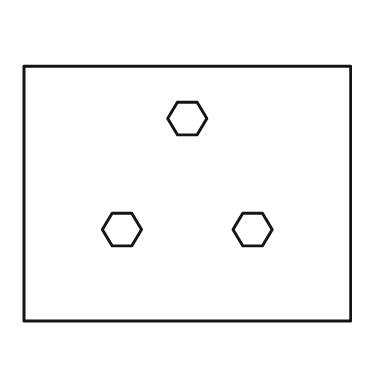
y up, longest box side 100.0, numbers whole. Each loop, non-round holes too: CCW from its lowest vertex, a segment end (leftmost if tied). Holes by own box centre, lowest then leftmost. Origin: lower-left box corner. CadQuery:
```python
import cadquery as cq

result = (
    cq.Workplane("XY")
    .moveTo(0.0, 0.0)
    .lineTo(100.0, 0.0)
    .lineTo(100.0, 78.0)
    .lineTo(0.0, 78.0)
    .close()
    .moveTo(27.0, 23.0)
    .lineTo(33.0, 23.0)
    .lineTo(36.0, 28.0)
    .lineTo(33.0, 33.0)
    .lineTo(27.0, 33.0)
    .lineTo(24.0, 28.0)
    .close()
    .moveTo(67.0, 23.0)
    .lineTo(73.0, 23.0)
    .lineTo(76.0, 28.0)
    .lineTo(73.0, 33.0)
    .lineTo(67.0, 33.0)
    .lineTo(64.0, 28.0)
    .close()
    .moveTo(47.0, 57.0)
    .lineTo(53.0, 57.0)
    .lineTo(56.0, 62.0)
    .lineTo(53.0, 67.0)
    .lineTo(47.0, 67.0)
    .lineTo(44.0, 62.0)
    .close()
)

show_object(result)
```